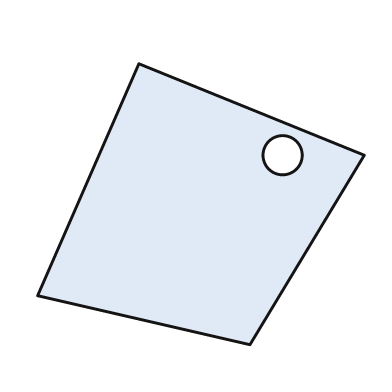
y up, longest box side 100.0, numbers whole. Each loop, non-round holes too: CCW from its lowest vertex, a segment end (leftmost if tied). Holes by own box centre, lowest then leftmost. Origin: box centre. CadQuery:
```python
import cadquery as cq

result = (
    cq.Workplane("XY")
    .moveTo(15.0, -43.0)
    .lineTo(50.0, 15.0)
    .lineTo(-19.0, 43.0)
    .lineTo(-50.0, -28.0)
    .close()
    .moveTo(25.0, 15.0)
    .circle(6.0)
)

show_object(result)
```